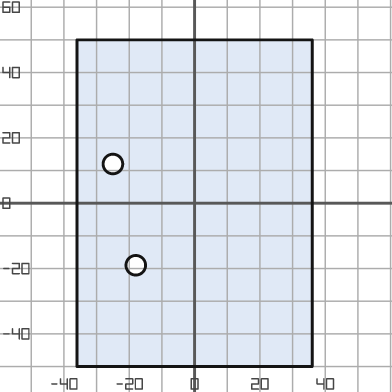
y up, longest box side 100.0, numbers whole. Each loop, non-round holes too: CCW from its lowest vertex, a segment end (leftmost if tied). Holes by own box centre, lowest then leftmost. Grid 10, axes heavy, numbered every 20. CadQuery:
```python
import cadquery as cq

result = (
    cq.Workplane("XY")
    .moveTo(-36.0, -50.0)
    .lineTo(36.0, -50.0)
    .lineTo(36.0, 50.0)
    .lineTo(-36.0, 50.0)
    .close()
    .moveTo(-18.0, -19.0)
    .circle(3.0)
    .moveTo(-25.0, 12.0)
    .circle(3.0)
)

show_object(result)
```